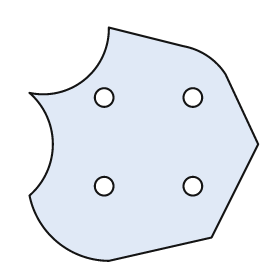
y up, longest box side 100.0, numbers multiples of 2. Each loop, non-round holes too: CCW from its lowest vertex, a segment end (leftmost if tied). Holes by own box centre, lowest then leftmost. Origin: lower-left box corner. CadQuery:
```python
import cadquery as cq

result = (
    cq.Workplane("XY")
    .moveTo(34.0, 0.0)
    .lineTo(78.0, 10.0)
    .lineTo(98.0, 50.0)
    .lineTo(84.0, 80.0)
    .threePointArc((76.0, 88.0), (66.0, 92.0))
    .lineTo(34.0, 100.0)
    .threePointArc((24.0, 78.0), (0.0, 72.0))
    .threePointArc((10.0, 50.0), (0.0, 28.0))
    .threePointArc((12.0, 8.0), (34.0, 0.0))
    .close()
    .moveTo(32.0, 32.0)
    .circle(4.0)
    .moveTo(70.0, 32.0)
    .circle(4.0)
    .moveTo(32.0, 70.0)
    .circle(4.0)
    .moveTo(70.0, 70.0)
    .circle(4.0)
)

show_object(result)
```